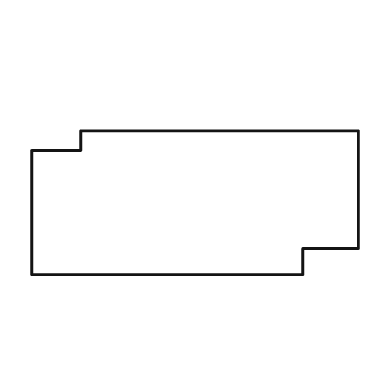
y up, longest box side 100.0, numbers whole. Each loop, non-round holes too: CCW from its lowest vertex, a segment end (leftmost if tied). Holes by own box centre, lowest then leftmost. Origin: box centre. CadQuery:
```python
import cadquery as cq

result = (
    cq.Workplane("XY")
    .moveTo(-50.0, -22.0)
    .lineTo(33.0, -22.0)
    .lineTo(33.0, -14.0)
    .lineTo(50.0, -14.0)
    .lineTo(50.0, 22.0)
    .lineTo(-35.0, 22.0)
    .lineTo(-35.0, 16.0)
    .lineTo(-50.0, 16.0)
    .close()
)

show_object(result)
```